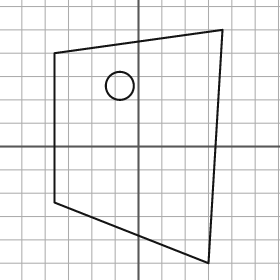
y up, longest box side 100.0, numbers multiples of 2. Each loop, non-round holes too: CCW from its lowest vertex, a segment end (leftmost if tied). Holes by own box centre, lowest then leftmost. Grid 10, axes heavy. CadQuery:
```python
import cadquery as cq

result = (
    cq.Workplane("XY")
    .moveTo(30.0, -50.0)
    .lineTo(36.0, 50.0)
    .lineTo(-36.0, 40.0)
    .lineTo(-36.0, -24.0)
    .close()
    .moveTo(-8.0, 26.0)
    .circle(6.0)
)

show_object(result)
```